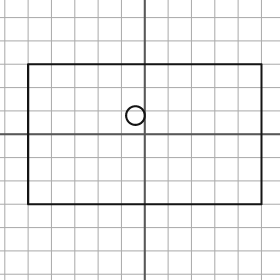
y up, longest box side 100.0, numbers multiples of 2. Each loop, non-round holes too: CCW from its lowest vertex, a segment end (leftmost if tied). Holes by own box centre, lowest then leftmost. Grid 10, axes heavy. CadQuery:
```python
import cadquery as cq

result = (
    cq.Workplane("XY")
    .moveTo(-50.0, -30.0)
    .lineTo(50.0, -30.0)
    .lineTo(50.0, 30.0)
    .lineTo(-50.0, 30.0)
    .close()
    .moveTo(-4.0, 8.0)
    .circle(4.0)
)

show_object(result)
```